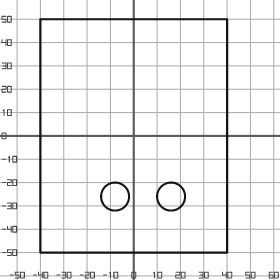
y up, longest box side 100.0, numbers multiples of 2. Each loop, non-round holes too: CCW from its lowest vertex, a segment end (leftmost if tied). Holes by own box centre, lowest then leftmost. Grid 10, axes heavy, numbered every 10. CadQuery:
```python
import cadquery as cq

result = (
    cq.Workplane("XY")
    .moveTo(-40.0, -50.0)
    .lineTo(40.0, -50.0)
    .lineTo(40.0, 50.0)
    .lineTo(-40.0, 50.0)
    .close()
    .moveTo(-8.0, -26.0)
    .circle(6.0)
    .moveTo(16.0, -26.0)
    .circle(6.0)
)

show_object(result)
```